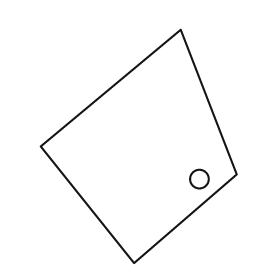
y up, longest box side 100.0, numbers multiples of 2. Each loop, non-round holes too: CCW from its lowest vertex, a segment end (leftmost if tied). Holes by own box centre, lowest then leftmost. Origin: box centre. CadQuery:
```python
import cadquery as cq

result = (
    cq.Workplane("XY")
    .moveTo(-2.0, -50.0)
    .lineTo(42.0, -12.0)
    .lineTo(18.0, 50.0)
    .lineTo(-42.0, 0.0)
    .close()
    .moveTo(26.0, -14.0)
    .circle(4.0)
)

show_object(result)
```